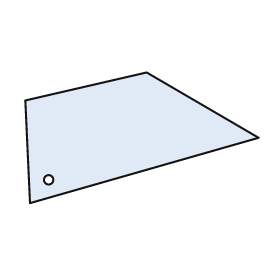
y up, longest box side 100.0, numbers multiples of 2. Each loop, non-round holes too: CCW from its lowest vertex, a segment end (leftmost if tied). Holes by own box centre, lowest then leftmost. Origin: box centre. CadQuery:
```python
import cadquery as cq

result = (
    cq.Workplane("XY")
    .moveTo(-48.0, -28.0)
    .lineTo(50.0, 0.0)
    .lineTo(2.0, 28.0)
    .lineTo(-50.0, 16.0)
    .close()
    .moveTo(-40.0, -18.0)
    .circle(2.0)
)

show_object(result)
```